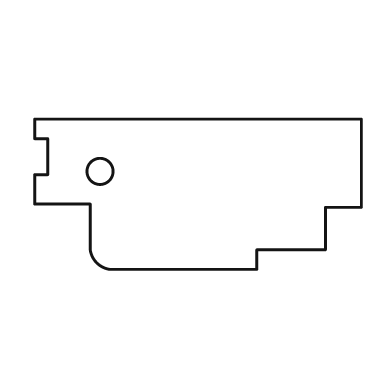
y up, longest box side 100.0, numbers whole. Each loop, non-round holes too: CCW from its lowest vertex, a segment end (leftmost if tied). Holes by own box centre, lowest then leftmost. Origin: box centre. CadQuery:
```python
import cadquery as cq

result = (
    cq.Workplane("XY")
    .moveTo(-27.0, -23.0)
    .lineTo(18.0, -23.0)
    .lineTo(18.0, -17.0)
    .lineTo(39.0, -17.0)
    .lineTo(39.0, -4.0)
    .lineTo(50.0, -4.0)
    .lineTo(50.0, 23.0)
    .lineTo(-50.0, 23.0)
    .lineTo(-50.0, 17.0)
    .lineTo(-46.0, 17.0)
    .lineTo(-46.0, 6.0)
    .lineTo(-50.0, 6.0)
    .lineTo(-50.0, -3.0)
    .lineTo(-33.0, -3.0)
    .lineTo(-33.0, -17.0)
    .threePointArc((-31.0, -21.0), (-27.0, -23.0))
    .close()
    .moveTo(-30.0, 7.0)
    .circle(4.0)
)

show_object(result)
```